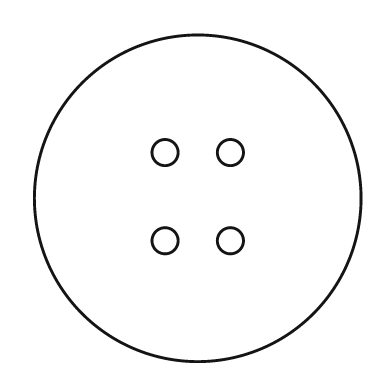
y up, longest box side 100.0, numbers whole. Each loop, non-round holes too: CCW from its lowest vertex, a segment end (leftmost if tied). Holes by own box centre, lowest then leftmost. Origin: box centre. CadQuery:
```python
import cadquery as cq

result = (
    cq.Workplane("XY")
    .moveTo(0.0, 0.0)
    .circle(50.0)
    .moveTo(-10.0, -13.0)
    .circle(4.0)
    .moveTo(10.0, -13.0)
    .circle(4.0)
    .moveTo(-10.0, 14.0)
    .circle(4.0)
    .moveTo(10.0, 14.0)
    .circle(4.0)
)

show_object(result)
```